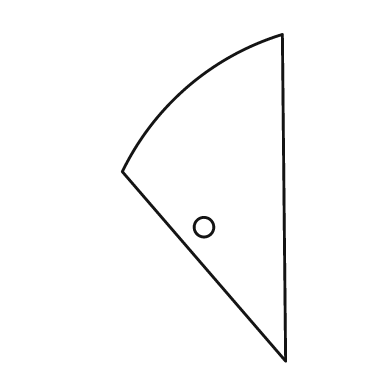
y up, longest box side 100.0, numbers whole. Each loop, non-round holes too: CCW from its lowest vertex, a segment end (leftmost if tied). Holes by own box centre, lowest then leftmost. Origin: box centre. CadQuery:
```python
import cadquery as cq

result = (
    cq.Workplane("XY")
    .moveTo(25.0, -50.0)
    .lineTo(24.0, 50.0)
    .threePointArc((-5.0, 34.0), (-25.0, 8.0))
    .close()
    .moveTo(0.0, -9.0)
    .circle(3.0)
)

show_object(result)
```